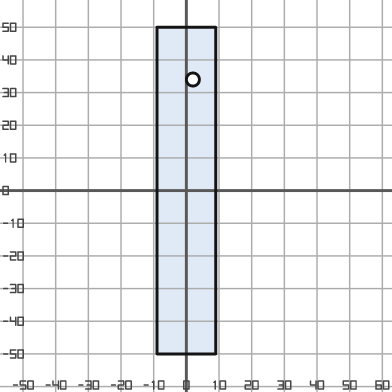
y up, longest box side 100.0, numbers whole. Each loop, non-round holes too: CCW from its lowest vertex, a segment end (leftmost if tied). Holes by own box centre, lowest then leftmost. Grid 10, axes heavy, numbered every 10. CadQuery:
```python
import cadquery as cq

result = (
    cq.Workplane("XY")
    .moveTo(-9.0, -50.0)
    .lineTo(9.0, -50.0)
    .lineTo(9.0, 50.0)
    .lineTo(-9.0, 50.0)
    .close()
    .moveTo(2.0, 34.0)
    .circle(2.0)
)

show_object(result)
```